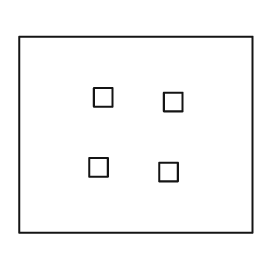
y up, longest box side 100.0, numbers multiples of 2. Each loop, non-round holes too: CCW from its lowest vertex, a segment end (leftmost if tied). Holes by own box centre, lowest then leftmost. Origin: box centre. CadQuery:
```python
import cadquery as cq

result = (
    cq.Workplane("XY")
    .moveTo(-50.0, -42.0)
    .lineTo(50.0, -42.0)
    .lineTo(50.0, 42.0)
    .lineTo(-50.0, 42.0)
    .close()
    .moveTo(10.0, -20.0)
    .lineTo(18.0, -20.0)
    .lineTo(18.0, -12.0)
    .lineTo(10.0, -12.0)
    .close()
    .moveTo(-20.0, -18.0)
    .lineTo(-12.0, -18.0)
    .lineTo(-12.0, -10.0)
    .lineTo(-20.0, -10.0)
    .close()
    .moveTo(12.0, 10.0)
    .lineTo(20.0, 10.0)
    .lineTo(20.0, 18.0)
    .lineTo(12.0, 18.0)
    .close()
    .moveTo(-18.0, 12.0)
    .lineTo(-10.0, 12.0)
    .lineTo(-10.0, 20.0)
    .lineTo(-18.0, 20.0)
    .close()
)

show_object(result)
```